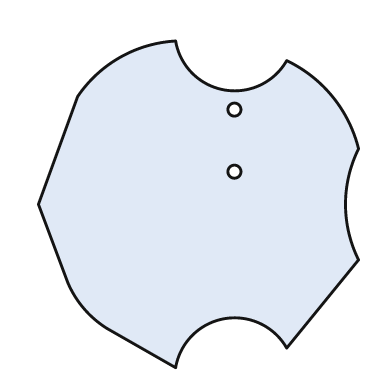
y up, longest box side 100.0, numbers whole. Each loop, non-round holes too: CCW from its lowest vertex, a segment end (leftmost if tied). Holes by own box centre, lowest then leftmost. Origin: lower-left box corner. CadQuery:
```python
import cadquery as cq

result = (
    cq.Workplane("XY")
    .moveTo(42.0, 0.0)
    .threePointArc((57.0, 15.0), (76.0, 6.0))
    .lineTo(98.0, 33.0)
    .threePointArc((94.0, 50.0), (98.0, 67.0))
    .threePointArc((90.0, 83.0), (76.0, 94.0))
    .threePointArc((57.0, 85.0), (42.0, 100.0))
    .threePointArc((25.0, 95.0), (12.0, 83.0))
    .lineTo(0.0, 50.0)
    .lineTo(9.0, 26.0)
    .threePointArc((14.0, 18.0), (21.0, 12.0))
    .close()
    .moveTo(60.0, 60.0)
    .circle(2.0)
    .moveTo(60.0, 79.0)
    .circle(2.0)
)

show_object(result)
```